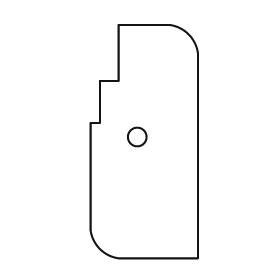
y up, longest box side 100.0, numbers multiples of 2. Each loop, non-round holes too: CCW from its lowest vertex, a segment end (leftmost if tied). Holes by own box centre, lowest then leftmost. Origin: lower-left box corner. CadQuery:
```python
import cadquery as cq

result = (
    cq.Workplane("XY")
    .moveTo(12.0, 0.0)
    .lineTo(46.0, 0.0)
    .lineTo(46.0, 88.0)
    .threePointArc((42.0, 96.0), (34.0, 100.0))
    .lineTo(12.0, 100.0)
    .lineTo(12.0, 76.0)
    .lineTo(4.0, 76.0)
    .lineTo(4.0, 58.0)
    .lineTo(0.0, 58.0)
    .lineTo(0.0, 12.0)
    .threePointArc((4.0, 4.0), (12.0, 0.0))
    .close()
    .moveTo(20.0, 52.0)
    .circle(4.0)
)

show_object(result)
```